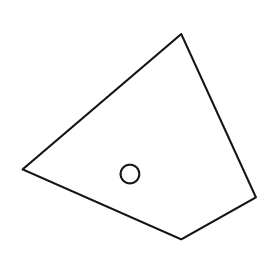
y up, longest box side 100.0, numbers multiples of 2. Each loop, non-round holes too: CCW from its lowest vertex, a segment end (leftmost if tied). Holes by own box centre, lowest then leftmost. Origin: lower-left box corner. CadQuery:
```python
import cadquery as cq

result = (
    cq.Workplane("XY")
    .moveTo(68.0, 0.0)
    .lineTo(100.0, 18.0)
    .lineTo(68.0, 88.0)
    .lineTo(0.0, 30.0)
    .close()
    .moveTo(46.0, 28.0)
    .circle(4.0)
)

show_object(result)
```